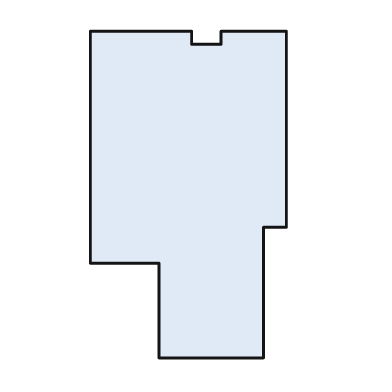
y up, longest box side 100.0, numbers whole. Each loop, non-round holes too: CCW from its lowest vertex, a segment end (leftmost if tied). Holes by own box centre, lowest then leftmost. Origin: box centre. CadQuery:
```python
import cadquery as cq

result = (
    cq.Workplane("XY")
    .moveTo(-9.0, -50.0)
    .lineTo(23.0, -50.0)
    .lineTo(23.0, -10.0)
    .lineTo(30.0, -10.0)
    .lineTo(30.0, 50.0)
    .lineTo(10.0, 50.0)
    .lineTo(10.0, 46.0)
    .lineTo(1.0, 46.0)
    .lineTo(1.0, 50.0)
    .lineTo(-30.0, 50.0)
    .lineTo(-30.0, -21.0)
    .lineTo(-9.0, -21.0)
    .close()
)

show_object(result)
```